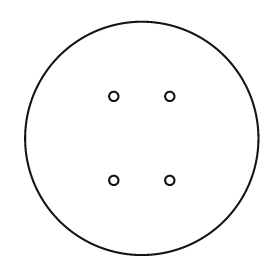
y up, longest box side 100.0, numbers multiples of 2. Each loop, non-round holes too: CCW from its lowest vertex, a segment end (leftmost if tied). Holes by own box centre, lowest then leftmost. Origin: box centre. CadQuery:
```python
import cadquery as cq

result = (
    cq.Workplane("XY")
    .moveTo(0.0, 0.0)
    .circle(50.0)
    .moveTo(-12.0, -18.0)
    .circle(2.0)
    .moveTo(12.0, -18.0)
    .circle(2.0)
    .moveTo(-12.0, 18.0)
    .circle(2.0)
    .moveTo(12.0, 18.0)
    .circle(2.0)
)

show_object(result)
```